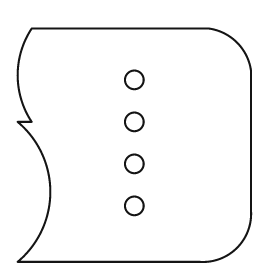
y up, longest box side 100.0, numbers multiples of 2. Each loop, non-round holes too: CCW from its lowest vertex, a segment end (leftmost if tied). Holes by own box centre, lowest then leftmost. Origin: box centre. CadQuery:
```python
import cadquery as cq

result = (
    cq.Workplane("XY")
    .moveTo(-50.0, -50.0)
    .lineTo(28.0, -50.0)
    .threePointArc((44.0, -44.0), (50.0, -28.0))
    .lineTo(50.0, 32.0)
    .threePointArc((44.0, 44.0), (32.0, 50.0))
    .lineTo(-44.0, 50.0)
    .threePointArc((-50.0, 30.0), (-44.0, 10.0))
    .lineTo(-50.0, 10.0)
    .threePointArc((-36.0, -20.0), (-50.0, -50.0))
    .close()
    .moveTo(0.0, -26.0)
    .circle(4.0)
    .moveTo(0.0, -8.0)
    .circle(4.0)
    .moveTo(0.0, 10.0)
    .circle(4.0)
    .moveTo(0.0, 28.0)
    .circle(4.0)
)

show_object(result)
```